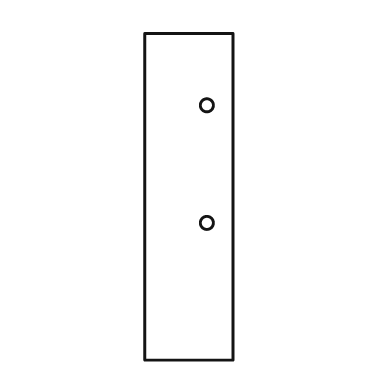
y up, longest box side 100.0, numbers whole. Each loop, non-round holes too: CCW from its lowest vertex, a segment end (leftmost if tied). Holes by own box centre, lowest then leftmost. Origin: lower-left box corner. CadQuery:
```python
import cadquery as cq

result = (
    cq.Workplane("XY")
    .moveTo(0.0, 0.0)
    .lineTo(27.0, 0.0)
    .lineTo(27.0, 100.0)
    .lineTo(0.0, 100.0)
    .close()
    .moveTo(19.0, 42.0)
    .circle(2.0)
    .moveTo(19.0, 78.0)
    .circle(2.0)
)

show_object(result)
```